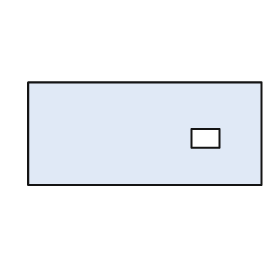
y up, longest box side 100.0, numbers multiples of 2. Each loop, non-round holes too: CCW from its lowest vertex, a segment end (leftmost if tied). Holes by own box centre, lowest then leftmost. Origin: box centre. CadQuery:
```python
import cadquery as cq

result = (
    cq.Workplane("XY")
    .moveTo(-50.0, -22.0)
    .lineTo(50.0, -22.0)
    .lineTo(50.0, 22.0)
    .lineTo(-50.0, 22.0)
    .close()
    .moveTo(20.0, -6.0)
    .lineTo(32.0, -6.0)
    .lineTo(32.0, 2.0)
    .lineTo(20.0, 2.0)
    .close()
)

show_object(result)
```